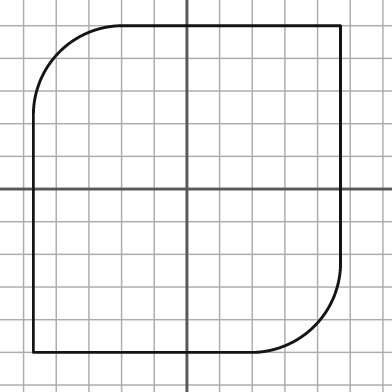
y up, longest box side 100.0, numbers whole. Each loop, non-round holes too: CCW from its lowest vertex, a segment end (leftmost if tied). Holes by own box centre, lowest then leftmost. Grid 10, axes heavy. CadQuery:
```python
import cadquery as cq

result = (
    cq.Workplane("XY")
    .moveTo(-47.0, -50.0)
    .lineTo(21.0, -50.0)
    .threePointArc((39.0, -42.0), (47.0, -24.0))
    .lineTo(47.0, 50.0)
    .lineTo(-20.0, 50.0)
    .threePointArc((-39.0, 42.0), (-47.0, 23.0))
    .close()
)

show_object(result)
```